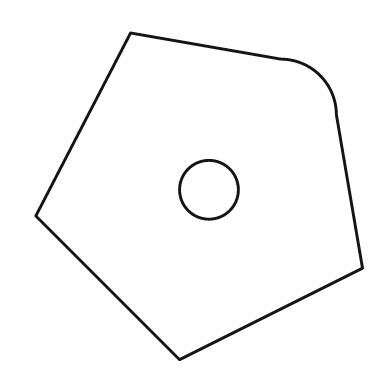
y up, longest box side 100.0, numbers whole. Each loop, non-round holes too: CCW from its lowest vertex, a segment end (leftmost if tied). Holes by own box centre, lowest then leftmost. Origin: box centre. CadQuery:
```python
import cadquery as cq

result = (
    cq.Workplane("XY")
    .moveTo(-6.0, -50.0)
    .lineTo(50.0, -22.0)
    .lineTo(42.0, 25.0)
    .threePointArc((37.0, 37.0), (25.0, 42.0))
    .lineTo(-21.0, 50.0)
    .lineTo(-50.0, -6.0)
    .close()
    .moveTo(3.0, 2.0)
    .circle(9.0)
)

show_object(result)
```